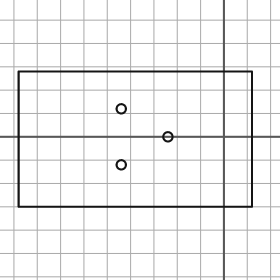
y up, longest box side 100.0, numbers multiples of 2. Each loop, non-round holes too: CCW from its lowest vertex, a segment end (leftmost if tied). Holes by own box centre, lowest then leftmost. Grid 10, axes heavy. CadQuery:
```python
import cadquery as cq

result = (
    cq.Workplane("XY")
    .moveTo(-88.0, -30.0)
    .lineTo(12.0, -30.0)
    .lineTo(12.0, 28.0)
    .lineTo(-88.0, 28.0)
    .close()
    .moveTo(-44.0, -12.0)
    .circle(2.0)
    .moveTo(-24.0, 0.0)
    .circle(2.0)
    .moveTo(-44.0, 12.0)
    .circle(2.0)
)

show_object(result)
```